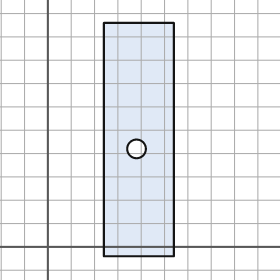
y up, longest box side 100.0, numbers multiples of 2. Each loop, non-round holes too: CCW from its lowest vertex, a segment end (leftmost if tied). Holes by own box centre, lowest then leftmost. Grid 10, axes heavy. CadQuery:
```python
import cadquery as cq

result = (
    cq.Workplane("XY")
    .moveTo(24.0, -4.0)
    .lineTo(54.0, -4.0)
    .lineTo(54.0, 96.0)
    .lineTo(24.0, 96.0)
    .close()
    .moveTo(38.0, 42.0)
    .circle(4.0)
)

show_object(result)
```